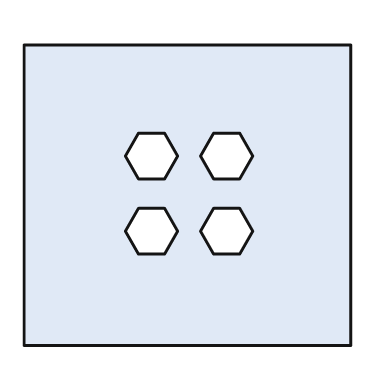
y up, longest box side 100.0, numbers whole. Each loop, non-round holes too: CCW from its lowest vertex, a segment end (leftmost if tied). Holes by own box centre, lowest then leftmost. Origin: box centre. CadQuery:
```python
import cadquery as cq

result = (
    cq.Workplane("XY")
    .moveTo(-50.0, -46.0)
    .lineTo(50.0, -46.0)
    .lineTo(50.0, 46.0)
    .lineTo(-50.0, 46.0)
    .close()
    .moveTo(-15.0, -18.0)
    .lineTo(-7.0, -18.0)
    .lineTo(-3.0, -11.0)
    .lineTo(-7.0, -4.0)
    .lineTo(-15.0, -4.0)
    .lineTo(-19.0, -11.0)
    .close()
    .moveTo(8.0, -18.0)
    .lineTo(16.0, -18.0)
    .lineTo(20.0, -11.0)
    .lineTo(16.0, -4.0)
    .lineTo(8.0, -4.0)
    .lineTo(4.0, -11.0)
    .close()
    .moveTo(-15.0, 5.0)
    .lineTo(-7.0, 5.0)
    .lineTo(-3.0, 12.0)
    .lineTo(-7.0, 19.0)
    .lineTo(-15.0, 19.0)
    .lineTo(-19.0, 12.0)
    .close()
    .moveTo(8.0, 5.0)
    .lineTo(16.0, 5.0)
    .lineTo(20.0, 12.0)
    .lineTo(16.0, 19.0)
    .lineTo(8.0, 19.0)
    .lineTo(4.0, 12.0)
    .close()
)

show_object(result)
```